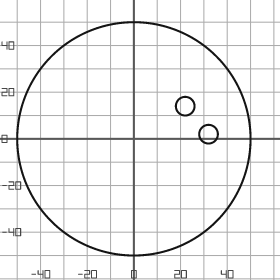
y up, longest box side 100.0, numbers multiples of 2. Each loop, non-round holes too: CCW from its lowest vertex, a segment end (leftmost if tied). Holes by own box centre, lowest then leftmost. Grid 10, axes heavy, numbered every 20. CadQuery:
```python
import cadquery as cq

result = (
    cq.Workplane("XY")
    .moveTo(0.0, 0.0)
    .circle(50.0)
    .moveTo(32.0, 2.0)
    .circle(4.0)
    .moveTo(22.0, 14.0)
    .circle(4.0)
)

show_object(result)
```